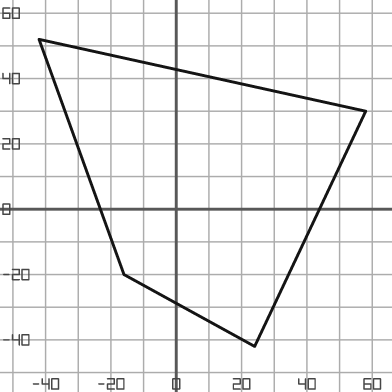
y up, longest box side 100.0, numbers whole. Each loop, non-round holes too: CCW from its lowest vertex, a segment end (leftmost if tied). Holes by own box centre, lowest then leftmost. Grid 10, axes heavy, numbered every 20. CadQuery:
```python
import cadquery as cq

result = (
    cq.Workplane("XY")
    .moveTo(24.0, -42.0)
    .lineTo(58.0, 30.0)
    .lineTo(-42.0, 52.0)
    .lineTo(-16.0, -20.0)
    .close()
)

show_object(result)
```